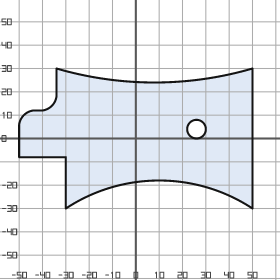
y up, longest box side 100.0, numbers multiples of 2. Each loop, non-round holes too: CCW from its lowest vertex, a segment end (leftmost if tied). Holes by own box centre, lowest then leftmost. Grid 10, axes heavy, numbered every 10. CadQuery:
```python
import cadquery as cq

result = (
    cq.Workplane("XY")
    .moveTo(-30.0, -30.0)
    .threePointArc((10.0, -18.0), (50.0, -30.0))
    .lineTo(50.0, 30.0)
    .threePointArc((8.0, 24.0), (-34.0, 30.0))
    .lineTo(-34.0, 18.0)
    .threePointArc((-36.0, 14.0), (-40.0, 12.0))
    .lineTo(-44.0, 12.0)
    .threePointArc((-48.0, 10.0), (-50.0, 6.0))
    .lineTo(-50.0, -8.0)
    .lineTo(-30.0, -8.0)
    .close()
    .moveTo(26.0, 4.0)
    .circle(4.0)
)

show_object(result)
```